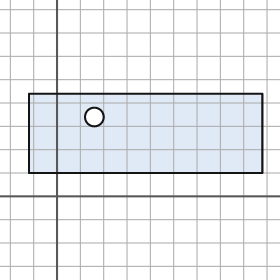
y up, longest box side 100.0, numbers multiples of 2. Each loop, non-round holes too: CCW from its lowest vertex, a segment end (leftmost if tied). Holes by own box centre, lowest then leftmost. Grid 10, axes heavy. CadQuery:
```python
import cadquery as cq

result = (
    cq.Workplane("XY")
    .moveTo(-12.0, 10.0)
    .lineTo(88.0, 10.0)
    .lineTo(88.0, 44.0)
    .lineTo(-12.0, 44.0)
    .close()
    .moveTo(16.0, 34.0)
    .circle(4.0)
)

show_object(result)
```